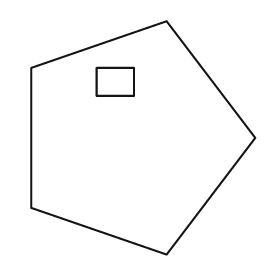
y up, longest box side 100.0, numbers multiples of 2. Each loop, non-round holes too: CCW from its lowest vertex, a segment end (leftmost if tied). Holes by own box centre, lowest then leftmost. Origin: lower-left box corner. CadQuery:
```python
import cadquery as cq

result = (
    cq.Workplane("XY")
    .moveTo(58.0, 0.0)
    .lineTo(96.0, 50.0)
    .lineTo(58.0, 100.0)
    .lineTo(0.0, 80.0)
    .lineTo(0.0, 20.0)
    .close()
    .moveTo(28.0, 68.0)
    .lineTo(44.0, 68.0)
    .lineTo(44.0, 80.0)
    .lineTo(28.0, 80.0)
    .close()
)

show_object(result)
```